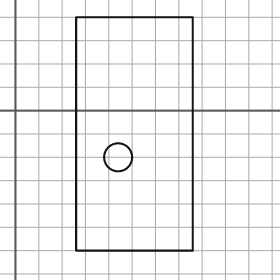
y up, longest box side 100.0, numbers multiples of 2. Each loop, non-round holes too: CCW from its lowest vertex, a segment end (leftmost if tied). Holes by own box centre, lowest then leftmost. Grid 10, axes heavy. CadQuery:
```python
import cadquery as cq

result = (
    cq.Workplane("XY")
    .moveTo(26.0, -60.0)
    .lineTo(76.0, -60.0)
    .lineTo(76.0, 40.0)
    .lineTo(26.0, 40.0)
    .close()
    .moveTo(44.0, -20.0)
    .circle(6.0)
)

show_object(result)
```